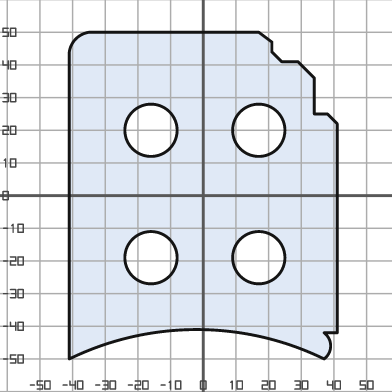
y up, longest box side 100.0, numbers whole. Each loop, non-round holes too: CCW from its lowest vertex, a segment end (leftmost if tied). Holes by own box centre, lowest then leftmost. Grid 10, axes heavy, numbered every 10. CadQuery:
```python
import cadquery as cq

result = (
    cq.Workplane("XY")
    .moveTo(-41.0, -50.0)
    .threePointArc((-2.0, -41.0), (37.0, -50.0))
    .threePointArc((39.0, -46.0), (37.0, -42.0))
    .lineTo(41.0, -42.0)
    .lineTo(41.0, 22.0)
    .lineTo(38.0, 25.0)
    .lineTo(34.0, 25.0)
    .lineTo(34.0, 36.0)
    .lineTo(29.0, 41.0)
    .lineTo(24.0, 41.0)
    .lineTo(21.0, 44.0)
    .lineTo(21.0, 47.0)
    .lineTo(17.0, 50.0)
    .lineTo(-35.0, 50.0)
    .threePointArc((-39.0, 48.0), (-41.0, 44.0))
    .close()
    .moveTo(-16.0, -19.0)
    .circle(8.0)
    .moveTo(17.0, -19.0)
    .circle(8.0)
    .moveTo(-16.0, 20.0)
    .circle(8.0)
    .moveTo(17.0, 20.0)
    .circle(8.0)
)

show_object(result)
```